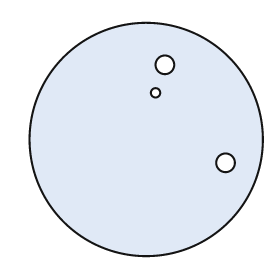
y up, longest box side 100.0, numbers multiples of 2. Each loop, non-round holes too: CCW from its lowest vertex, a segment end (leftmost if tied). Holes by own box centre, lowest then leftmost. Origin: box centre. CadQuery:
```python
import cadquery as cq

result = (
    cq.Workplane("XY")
    .moveTo(0.0, 0.0)
    .circle(50.0)
    .moveTo(34.0, -10.0)
    .circle(4.0)
    .moveTo(4.0, 20.0)
    .circle(2.0)
    .moveTo(8.0, 32.0)
    .circle(4.0)
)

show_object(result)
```